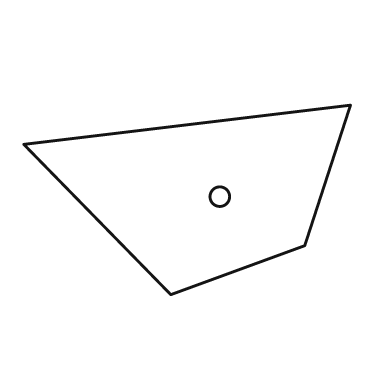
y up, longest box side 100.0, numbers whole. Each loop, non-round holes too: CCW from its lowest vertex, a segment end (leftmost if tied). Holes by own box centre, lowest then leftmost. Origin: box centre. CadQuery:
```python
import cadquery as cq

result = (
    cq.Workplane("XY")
    .moveTo(-5.0, -29.0)
    .lineTo(36.0, -14.0)
    .lineTo(50.0, 29.0)
    .lineTo(-50.0, 17.0)
    .close()
    .moveTo(10.0, 1.0)
    .circle(3.0)
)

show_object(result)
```